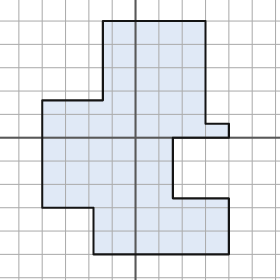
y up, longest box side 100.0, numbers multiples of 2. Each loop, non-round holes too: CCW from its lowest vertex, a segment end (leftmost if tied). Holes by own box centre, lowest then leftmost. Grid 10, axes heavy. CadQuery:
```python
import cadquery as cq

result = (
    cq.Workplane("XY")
    .moveTo(-18.0, -50.0)
    .lineTo(40.0, -50.0)
    .lineTo(40.0, -26.0)
    .lineTo(16.0, -26.0)
    .lineTo(16.0, 0.0)
    .lineTo(40.0, 0.0)
    .lineTo(40.0, 6.0)
    .lineTo(30.0, 6.0)
    .lineTo(30.0, 50.0)
    .lineTo(-14.0, 50.0)
    .lineTo(-14.0, 16.0)
    .lineTo(-40.0, 16.0)
    .lineTo(-40.0, -30.0)
    .lineTo(-18.0, -30.0)
    .close()
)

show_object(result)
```